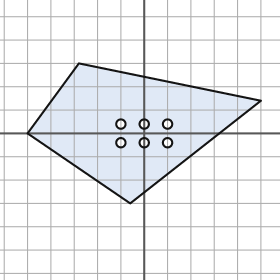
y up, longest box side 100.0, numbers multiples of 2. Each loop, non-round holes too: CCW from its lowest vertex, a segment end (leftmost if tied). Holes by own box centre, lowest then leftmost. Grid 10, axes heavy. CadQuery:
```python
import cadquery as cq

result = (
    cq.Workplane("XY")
    .moveTo(-6.0, -30.0)
    .lineTo(50.0, 14.0)
    .lineTo(-28.0, 30.0)
    .lineTo(-50.0, 0.0)
    .close()
    .moveTo(-10.0, -4.0)
    .circle(2.0)
    .moveTo(0.0, -4.0)
    .circle(2.0)
    .moveTo(10.0, -4.0)
    .circle(2.0)
    .moveTo(-10.0, 4.0)
    .circle(2.0)
    .moveTo(0.0, 4.0)
    .circle(2.0)
    .moveTo(10.0, 4.0)
    .circle(2.0)
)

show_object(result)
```